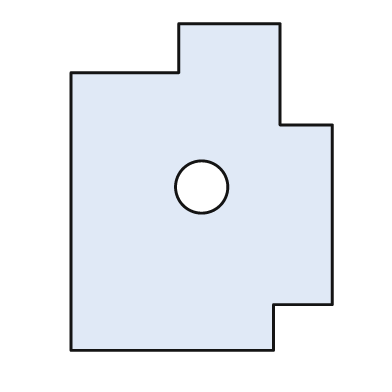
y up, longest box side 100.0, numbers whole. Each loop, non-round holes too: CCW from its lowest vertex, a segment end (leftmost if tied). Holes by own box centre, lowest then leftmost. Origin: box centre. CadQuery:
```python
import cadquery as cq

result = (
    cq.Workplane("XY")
    .moveTo(-40.0, -50.0)
    .lineTo(22.0, -50.0)
    .lineTo(22.0, -36.0)
    .lineTo(40.0, -36.0)
    .lineTo(40.0, 19.0)
    .lineTo(24.0, 19.0)
    .lineTo(24.0, 50.0)
    .lineTo(-7.0, 50.0)
    .lineTo(-7.0, 35.0)
    .lineTo(-40.0, 35.0)
    .close()
    .moveTo(0.0, 0.0)
    .circle(8.0)
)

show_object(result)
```